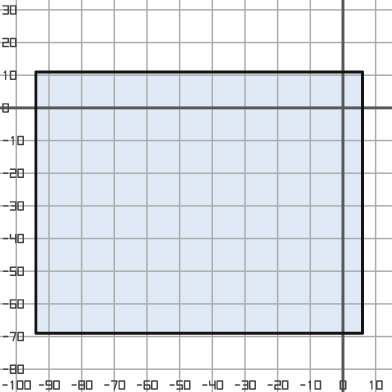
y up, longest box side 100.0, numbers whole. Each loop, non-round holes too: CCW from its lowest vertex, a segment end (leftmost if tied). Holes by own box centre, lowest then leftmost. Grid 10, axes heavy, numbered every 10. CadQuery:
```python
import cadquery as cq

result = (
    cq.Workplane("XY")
    .moveTo(-94.0, -69.0)
    .lineTo(6.0, -69.0)
    .lineTo(6.0, 11.0)
    .lineTo(-94.0, 11.0)
    .close()
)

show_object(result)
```